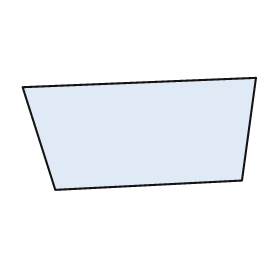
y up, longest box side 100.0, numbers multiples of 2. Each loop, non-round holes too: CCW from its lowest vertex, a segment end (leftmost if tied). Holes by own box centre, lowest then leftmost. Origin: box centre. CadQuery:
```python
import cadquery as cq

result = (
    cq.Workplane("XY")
    .moveTo(-36.0, -24.0)
    .lineTo(44.0, -20.0)
    .lineTo(50.0, 24.0)
    .lineTo(-50.0, 20.0)
    .close()
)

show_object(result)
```